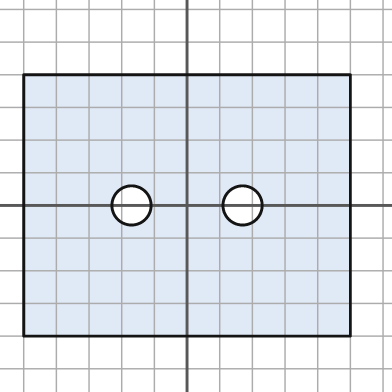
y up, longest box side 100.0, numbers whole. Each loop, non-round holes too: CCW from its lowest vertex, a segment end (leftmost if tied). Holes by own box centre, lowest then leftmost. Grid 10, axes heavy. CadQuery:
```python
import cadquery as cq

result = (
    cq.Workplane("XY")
    .moveTo(-50.0, -40.0)
    .lineTo(50.0, -40.0)
    .lineTo(50.0, 40.0)
    .lineTo(-50.0, 40.0)
    .close()
    .moveTo(-17.0, 0.0)
    .circle(6.0)
    .moveTo(17.0, 0.0)
    .circle(6.0)
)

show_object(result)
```